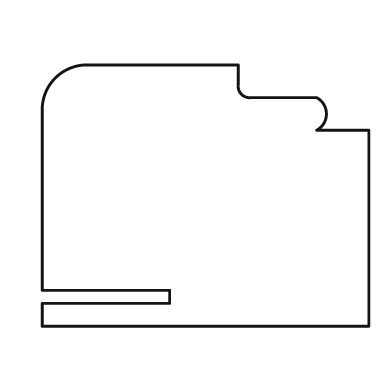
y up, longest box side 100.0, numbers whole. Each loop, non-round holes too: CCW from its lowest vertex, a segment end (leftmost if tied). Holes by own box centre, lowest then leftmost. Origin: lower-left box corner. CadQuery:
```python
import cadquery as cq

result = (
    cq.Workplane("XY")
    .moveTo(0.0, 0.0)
    .lineTo(100.0, 0.0)
    .lineTo(100.0, 60.0)
    .lineTo(84.0, 60.0)
    .threePointArc((87.0, 65.0), (84.0, 70.0))
    .lineTo(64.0, 70.0)
    .threePointArc((61.0, 71.0), (60.0, 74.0))
    .lineTo(60.0, 80.0)
    .lineTo(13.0, 80.0)
    .threePointArc((4.0, 76.0), (0.0, 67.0))
    .lineTo(0.0, 11.0)
    .lineTo(39.0, 11.0)
    .lineTo(39.0, 7.0)
    .lineTo(0.0, 7.0)
    .close()
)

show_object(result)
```